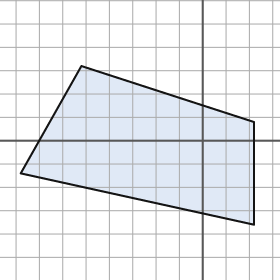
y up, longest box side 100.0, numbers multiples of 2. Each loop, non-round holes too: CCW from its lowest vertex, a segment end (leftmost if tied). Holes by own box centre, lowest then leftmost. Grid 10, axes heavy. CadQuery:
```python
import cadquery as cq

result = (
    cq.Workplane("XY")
    .moveTo(22.0, -36.0)
    .lineTo(22.0, 8.0)
    .lineTo(-52.0, 32.0)
    .lineTo(-78.0, -14.0)
    .close()
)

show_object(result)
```